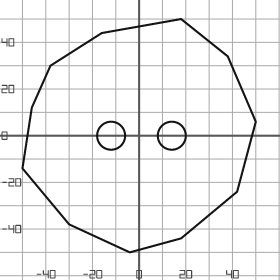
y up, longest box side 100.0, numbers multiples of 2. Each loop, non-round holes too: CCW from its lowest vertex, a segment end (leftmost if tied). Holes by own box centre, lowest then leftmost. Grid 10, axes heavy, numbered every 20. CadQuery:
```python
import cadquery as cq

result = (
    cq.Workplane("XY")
    .moveTo(-4.0, -50.0)
    .lineTo(18.0, -44.0)
    .lineTo(42.0, -24.0)
    .lineTo(50.0, 6.0)
    .lineTo(38.0, 34.0)
    .lineTo(18.0, 50.0)
    .lineTo(-16.0, 44.0)
    .lineTo(-38.0, 30.0)
    .lineTo(-46.0, 12.0)
    .lineTo(-50.0, -14.0)
    .lineTo(-30.0, -38.0)
    .close()
    .moveTo(-12.0, 0.0)
    .circle(6.0)
    .moveTo(14.0, 0.0)
    .circle(6.0)
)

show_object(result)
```